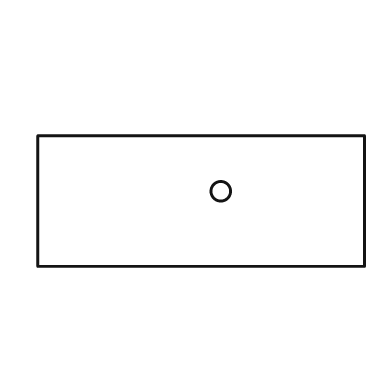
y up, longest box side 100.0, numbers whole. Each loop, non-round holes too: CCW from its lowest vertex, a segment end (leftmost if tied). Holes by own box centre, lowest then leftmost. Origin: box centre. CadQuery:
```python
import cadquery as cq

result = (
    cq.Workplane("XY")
    .moveTo(-50.0, -20.0)
    .lineTo(50.0, -20.0)
    .lineTo(50.0, 20.0)
    .lineTo(-50.0, 20.0)
    .close()
    .moveTo(6.0, 3.0)
    .circle(3.0)
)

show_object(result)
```